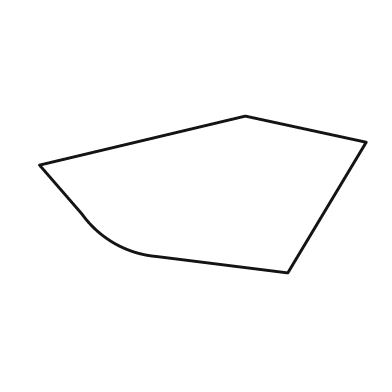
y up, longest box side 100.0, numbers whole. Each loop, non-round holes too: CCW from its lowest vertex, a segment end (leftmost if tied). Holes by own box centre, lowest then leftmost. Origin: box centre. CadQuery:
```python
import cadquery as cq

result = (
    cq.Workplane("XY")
    .moveTo(26.0, -24.0)
    .lineTo(50.0, 16.0)
    .lineTo(13.0, 24.0)
    .lineTo(-50.0, 9.0)
    .lineTo(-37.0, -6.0)
    .threePointArc((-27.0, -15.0), (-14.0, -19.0))
    .close()
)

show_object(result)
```